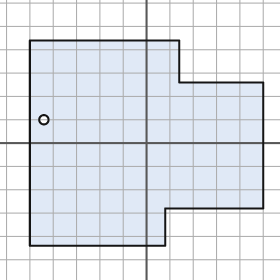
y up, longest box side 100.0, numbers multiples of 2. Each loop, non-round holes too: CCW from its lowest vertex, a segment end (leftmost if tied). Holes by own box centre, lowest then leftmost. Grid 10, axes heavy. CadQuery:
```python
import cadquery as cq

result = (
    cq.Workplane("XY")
    .moveTo(-50.0, -44.0)
    .lineTo(8.0, -44.0)
    .lineTo(8.0, -28.0)
    .lineTo(50.0, -28.0)
    .lineTo(50.0, 26.0)
    .lineTo(14.0, 26.0)
    .lineTo(14.0, 44.0)
    .lineTo(-50.0, 44.0)
    .close()
    .moveTo(-44.0, 10.0)
    .circle(2.0)
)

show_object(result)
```